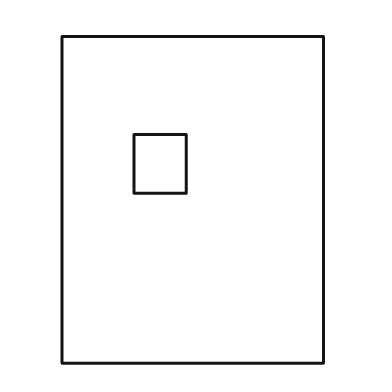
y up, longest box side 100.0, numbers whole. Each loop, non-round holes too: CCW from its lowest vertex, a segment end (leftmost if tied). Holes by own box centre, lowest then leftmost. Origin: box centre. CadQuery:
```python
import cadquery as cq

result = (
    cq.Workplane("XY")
    .moveTo(-40.0, -50.0)
    .lineTo(40.0, -50.0)
    .lineTo(40.0, 50.0)
    .lineTo(-40.0, 50.0)
    .close()
    .moveTo(-18.0, 2.0)
    .lineTo(-2.0, 2.0)
    .lineTo(-2.0, 20.0)
    .lineTo(-18.0, 20.0)
    .close()
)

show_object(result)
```